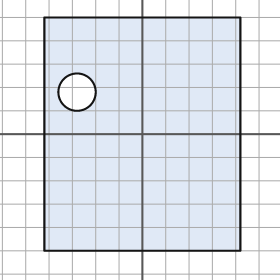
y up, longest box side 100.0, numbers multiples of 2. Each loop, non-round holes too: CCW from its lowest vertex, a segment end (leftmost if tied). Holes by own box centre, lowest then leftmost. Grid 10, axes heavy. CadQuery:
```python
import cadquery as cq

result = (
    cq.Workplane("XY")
    .moveTo(-42.0, -50.0)
    .lineTo(42.0, -50.0)
    .lineTo(42.0, 50.0)
    .lineTo(-42.0, 50.0)
    .close()
    .moveTo(-28.0, 18.0)
    .circle(8.0)
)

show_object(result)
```